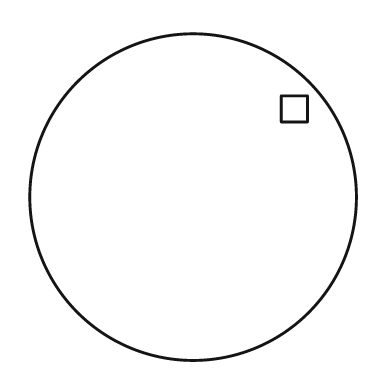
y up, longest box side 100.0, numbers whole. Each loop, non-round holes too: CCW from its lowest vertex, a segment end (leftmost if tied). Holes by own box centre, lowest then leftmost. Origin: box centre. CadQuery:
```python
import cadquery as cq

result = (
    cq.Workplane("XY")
    .moveTo(0.0, 0.0)
    .circle(50.0)
    .moveTo(27.0, 23.0)
    .lineTo(35.0, 23.0)
    .lineTo(35.0, 31.0)
    .lineTo(27.0, 31.0)
    .close()
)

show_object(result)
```